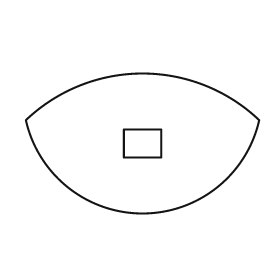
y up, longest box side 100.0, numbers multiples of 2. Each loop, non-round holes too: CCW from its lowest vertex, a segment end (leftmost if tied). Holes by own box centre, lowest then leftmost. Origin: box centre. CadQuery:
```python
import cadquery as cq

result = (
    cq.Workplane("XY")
    .moveTo(-50.0, 10.0)
    .threePointArc((0.0, -30.0), (50.0, 10.0))
    .threePointArc((0.0, 30.0), (-50.0, 10.0))
    .close()
    .moveTo(-8.0, -6.0)
    .lineTo(8.0, -6.0)
    .lineTo(8.0, 6.0)
    .lineTo(-8.0, 6.0)
    .close()
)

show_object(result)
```